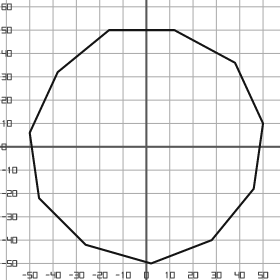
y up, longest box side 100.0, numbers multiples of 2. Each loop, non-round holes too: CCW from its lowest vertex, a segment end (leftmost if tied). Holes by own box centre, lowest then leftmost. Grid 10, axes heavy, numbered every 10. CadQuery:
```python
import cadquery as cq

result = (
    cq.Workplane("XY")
    .moveTo(2.0, -50.0)
    .lineTo(28.0, -40.0)
    .lineTo(46.0, -18.0)
    .lineTo(50.0, 10.0)
    .lineTo(38.0, 36.0)
    .lineTo(12.0, 50.0)
    .lineTo(-16.0, 50.0)
    .lineTo(-38.0, 32.0)
    .lineTo(-50.0, 6.0)
    .lineTo(-46.0, -22.0)
    .lineTo(-26.0, -42.0)
    .close()
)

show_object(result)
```